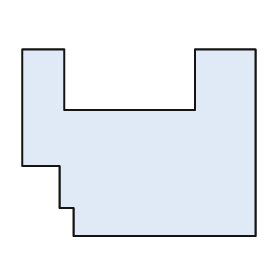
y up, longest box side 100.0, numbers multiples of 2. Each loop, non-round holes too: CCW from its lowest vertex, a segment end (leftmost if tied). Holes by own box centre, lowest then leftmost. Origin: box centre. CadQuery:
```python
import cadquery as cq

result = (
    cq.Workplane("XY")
    .moveTo(-28.0, -40.0)
    .lineTo(50.0, -40.0)
    .lineTo(50.0, 40.0)
    .lineTo(24.0, 40.0)
    .lineTo(24.0, 14.0)
    .lineTo(-32.0, 14.0)
    .lineTo(-32.0, 40.0)
    .lineTo(-50.0, 40.0)
    .lineTo(-50.0, -10.0)
    .lineTo(-34.0, -10.0)
    .lineTo(-34.0, -28.0)
    .lineTo(-28.0, -28.0)
    .close()
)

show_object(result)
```